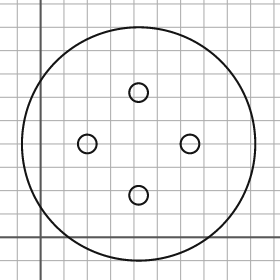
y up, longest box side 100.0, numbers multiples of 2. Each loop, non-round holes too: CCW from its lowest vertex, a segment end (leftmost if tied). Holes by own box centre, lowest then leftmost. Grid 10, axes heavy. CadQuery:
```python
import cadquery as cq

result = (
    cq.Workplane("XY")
    .moveTo(42.0, 40.0)
    .circle(50.0)
    .moveTo(42.0, 18.0)
    .circle(4.0)
    .moveTo(20.0, 40.0)
    .circle(4.0)
    .moveTo(64.0, 40.0)
    .circle(4.0)
    .moveTo(42.0, 62.0)
    .circle(4.0)
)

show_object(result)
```